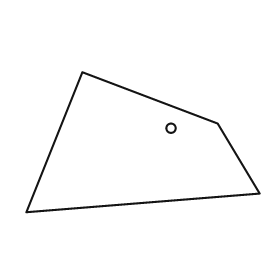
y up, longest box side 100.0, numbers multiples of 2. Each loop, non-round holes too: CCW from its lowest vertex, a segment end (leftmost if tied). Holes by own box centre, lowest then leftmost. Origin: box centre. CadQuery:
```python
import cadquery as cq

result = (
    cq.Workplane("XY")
    .moveTo(-50.0, -30.0)
    .lineTo(50.0, -22.0)
    .lineTo(32.0, 8.0)
    .lineTo(-26.0, 30.0)
    .close()
    .moveTo(12.0, 6.0)
    .circle(2.0)
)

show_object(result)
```